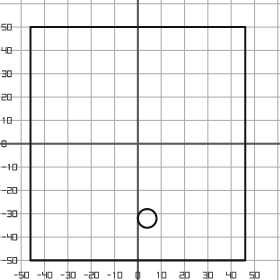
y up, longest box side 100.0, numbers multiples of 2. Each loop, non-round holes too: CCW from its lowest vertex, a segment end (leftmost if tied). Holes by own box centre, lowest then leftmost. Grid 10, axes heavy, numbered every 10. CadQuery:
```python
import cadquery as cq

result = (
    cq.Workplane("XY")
    .moveTo(-46.0, -50.0)
    .lineTo(46.0, -50.0)
    .lineTo(46.0, 50.0)
    .lineTo(-46.0, 50.0)
    .close()
    .moveTo(4.0, -32.0)
    .circle(4.0)
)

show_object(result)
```